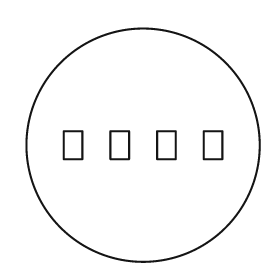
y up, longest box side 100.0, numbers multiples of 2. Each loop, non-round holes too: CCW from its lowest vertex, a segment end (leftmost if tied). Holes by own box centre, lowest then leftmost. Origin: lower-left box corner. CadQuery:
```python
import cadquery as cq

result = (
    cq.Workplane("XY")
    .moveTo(50.0, 50.0)
    .circle(50.0)
    .moveTo(16.0, 44.0)
    .lineTo(24.0, 44.0)
    .lineTo(24.0, 56.0)
    .lineTo(16.0, 56.0)
    .close()
    .moveTo(36.0, 44.0)
    .lineTo(44.0, 44.0)
    .lineTo(44.0, 56.0)
    .lineTo(36.0, 56.0)
    .close()
    .moveTo(56.0, 44.0)
    .lineTo(64.0, 44.0)
    .lineTo(64.0, 56.0)
    .lineTo(56.0, 56.0)
    .close()
    .moveTo(76.0, 44.0)
    .lineTo(84.0, 44.0)
    .lineTo(84.0, 56.0)
    .lineTo(76.0, 56.0)
    .close()
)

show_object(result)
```